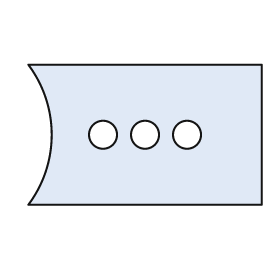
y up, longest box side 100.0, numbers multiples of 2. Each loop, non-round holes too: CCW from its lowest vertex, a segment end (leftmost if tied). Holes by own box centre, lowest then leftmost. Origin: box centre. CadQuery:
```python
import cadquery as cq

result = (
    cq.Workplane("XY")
    .moveTo(-50.0, -30.0)
    .lineTo(50.0, -30.0)
    .lineTo(50.0, 30.0)
    .lineTo(-50.0, 30.0)
    .threePointArc((-40.0, 0.0), (-50.0, -30.0))
    .close()
    .moveTo(-18.0, 0.0)
    .circle(6.0)
    .moveTo(0.0, 0.0)
    .circle(6.0)
    .moveTo(18.0, 0.0)
    .circle(6.0)
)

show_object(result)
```